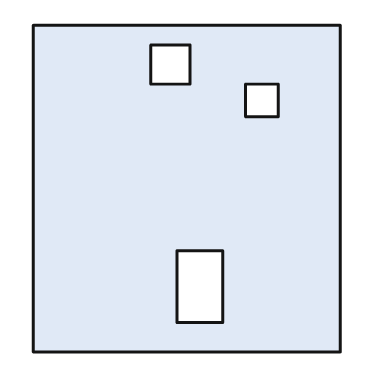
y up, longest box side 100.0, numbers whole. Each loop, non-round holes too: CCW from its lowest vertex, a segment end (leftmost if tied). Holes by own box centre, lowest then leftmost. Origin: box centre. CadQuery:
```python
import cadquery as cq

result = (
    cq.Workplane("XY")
    .moveTo(-47.0, -50.0)
    .lineTo(47.0, -50.0)
    .lineTo(47.0, 50.0)
    .lineTo(-47.0, 50.0)
    .close()
    .moveTo(-3.0, -41.0)
    .lineTo(11.0, -41.0)
    .lineTo(11.0, -19.0)
    .lineTo(-3.0, -19.0)
    .close()
    .moveTo(18.0, 22.0)
    .lineTo(28.0, 22.0)
    .lineTo(28.0, 32.0)
    .lineTo(18.0, 32.0)
    .close()
    .moveTo(-11.0, 32.0)
    .lineTo(1.0, 32.0)
    .lineTo(1.0, 44.0)
    .lineTo(-11.0, 44.0)
    .close()
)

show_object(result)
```